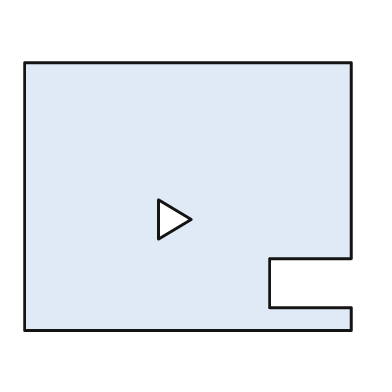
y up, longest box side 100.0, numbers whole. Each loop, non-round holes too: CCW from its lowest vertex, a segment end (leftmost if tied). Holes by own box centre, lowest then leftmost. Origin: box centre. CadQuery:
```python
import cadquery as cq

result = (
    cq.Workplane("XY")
    .moveTo(-50.0, -41.0)
    .lineTo(50.0, -41.0)
    .lineTo(50.0, -34.0)
    .lineTo(25.0, -34.0)
    .lineTo(25.0, -19.0)
    .lineTo(50.0, -19.0)
    .lineTo(50.0, 41.0)
    .lineTo(-50.0, 41.0)
    .close()
    .moveTo(-9.0, -13.0)
    .lineTo(1.0, -7.0)
    .lineTo(-9.0, -1.0)
    .close()
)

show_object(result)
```